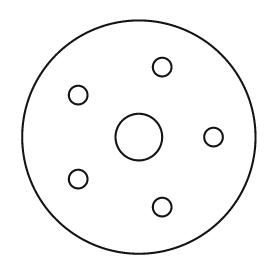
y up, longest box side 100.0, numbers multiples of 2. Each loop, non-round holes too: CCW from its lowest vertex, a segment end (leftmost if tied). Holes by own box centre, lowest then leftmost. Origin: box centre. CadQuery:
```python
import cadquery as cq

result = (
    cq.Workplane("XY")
    .moveTo(0.0, 0.0)
    .circle(50.0)
    .moveTo(10.0, -30.0)
    .circle(4.0)
    .moveTo(-26.0, -18.0)
    .circle(4.0)
    .moveTo(0.0, 0.0)
    .circle(10.0)
    .moveTo(32.0, 0.0)
    .circle(4.0)
    .moveTo(-26.0, 18.0)
    .circle(4.0)
    .moveTo(10.0, 30.0)
    .circle(4.0)
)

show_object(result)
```